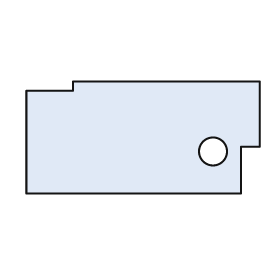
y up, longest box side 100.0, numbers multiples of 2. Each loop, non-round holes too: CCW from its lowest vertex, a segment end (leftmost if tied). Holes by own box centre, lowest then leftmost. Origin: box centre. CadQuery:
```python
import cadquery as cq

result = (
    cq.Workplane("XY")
    .moveTo(-50.0, -24.0)
    .lineTo(42.0, -24.0)
    .lineTo(42.0, -4.0)
    .lineTo(50.0, -4.0)
    .lineTo(50.0, 24.0)
    .lineTo(-30.0, 24.0)
    .lineTo(-30.0, 20.0)
    .lineTo(-50.0, 20.0)
    .close()
    .moveTo(30.0, -6.0)
    .circle(6.0)
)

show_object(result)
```